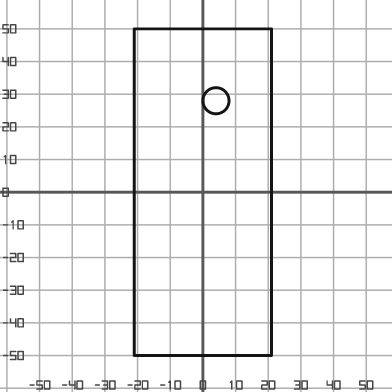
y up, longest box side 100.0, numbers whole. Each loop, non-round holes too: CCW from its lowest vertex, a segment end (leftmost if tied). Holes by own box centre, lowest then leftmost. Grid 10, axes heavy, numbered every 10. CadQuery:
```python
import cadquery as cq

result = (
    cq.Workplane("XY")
    .moveTo(-21.0, -50.0)
    .lineTo(21.0, -50.0)
    .lineTo(21.0, 50.0)
    .lineTo(-21.0, 50.0)
    .close()
    .moveTo(4.0, 28.0)
    .circle(4.0)
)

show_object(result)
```